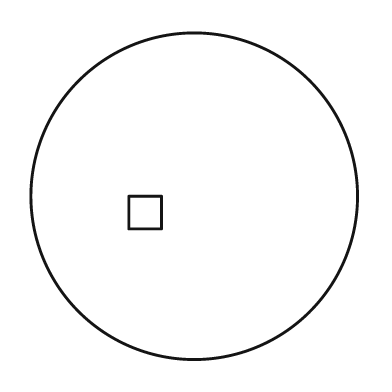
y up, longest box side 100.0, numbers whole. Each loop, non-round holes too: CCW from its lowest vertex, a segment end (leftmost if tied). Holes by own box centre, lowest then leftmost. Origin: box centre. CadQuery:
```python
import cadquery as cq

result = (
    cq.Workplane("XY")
    .moveTo(0.0, 0.0)
    .circle(50.0)
    .moveTo(-20.0, -10.0)
    .lineTo(-10.0, -10.0)
    .lineTo(-10.0, 0.0)
    .lineTo(-20.0, 0.0)
    .close()
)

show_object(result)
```